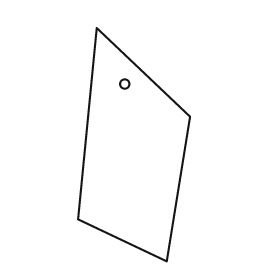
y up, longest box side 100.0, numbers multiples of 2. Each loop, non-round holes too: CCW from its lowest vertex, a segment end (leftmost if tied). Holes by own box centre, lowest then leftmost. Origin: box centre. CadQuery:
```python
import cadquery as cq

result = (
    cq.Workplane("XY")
    .moveTo(14.0, -50.0)
    .lineTo(24.0, 12.0)
    .lineTo(-16.0, 50.0)
    .lineTo(-24.0, -32.0)
    .close()
    .moveTo(-4.0, 26.0)
    .circle(2.0)
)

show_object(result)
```